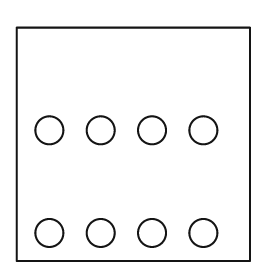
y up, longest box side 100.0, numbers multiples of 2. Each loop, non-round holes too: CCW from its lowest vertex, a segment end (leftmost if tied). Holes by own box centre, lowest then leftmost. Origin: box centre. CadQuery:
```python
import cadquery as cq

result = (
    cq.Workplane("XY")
    .moveTo(-50.0, -50.0)
    .lineTo(50.0, -50.0)
    .lineTo(50.0, 50.0)
    .lineTo(-50.0, 50.0)
    .close()
    .moveTo(-36.0, -38.0)
    .circle(6.0)
    .moveTo(-14.0, -38.0)
    .circle(6.0)
    .moveTo(8.0, -38.0)
    .circle(6.0)
    .moveTo(30.0, -38.0)
    .circle(6.0)
    .moveTo(-36.0, 6.0)
    .circle(6.0)
    .moveTo(-14.0, 6.0)
    .circle(6.0)
    .moveTo(8.0, 6.0)
    .circle(6.0)
    .moveTo(30.0, 6.0)
    .circle(6.0)
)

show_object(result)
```